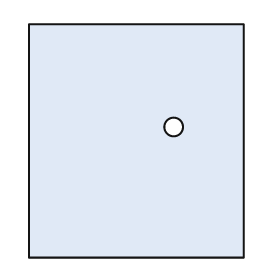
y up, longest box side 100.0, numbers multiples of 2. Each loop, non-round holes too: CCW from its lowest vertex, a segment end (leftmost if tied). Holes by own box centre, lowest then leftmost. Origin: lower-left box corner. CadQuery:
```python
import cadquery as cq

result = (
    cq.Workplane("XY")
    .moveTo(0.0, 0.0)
    .lineTo(92.0, 0.0)
    .lineTo(92.0, 100.0)
    .lineTo(0.0, 100.0)
    .close()
    .moveTo(62.0, 56.0)
    .circle(4.0)
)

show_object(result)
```